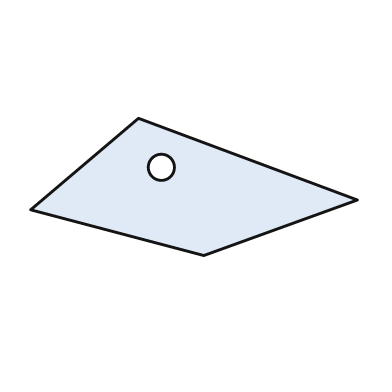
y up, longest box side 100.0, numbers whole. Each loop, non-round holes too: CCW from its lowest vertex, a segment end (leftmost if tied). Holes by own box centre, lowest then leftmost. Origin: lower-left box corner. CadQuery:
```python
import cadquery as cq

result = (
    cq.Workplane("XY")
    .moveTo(53.0, 0.0)
    .lineTo(100.0, 17.0)
    .lineTo(33.0, 42.0)
    .lineTo(0.0, 14.0)
    .close()
    .moveTo(40.0, 27.0)
    .circle(4.0)
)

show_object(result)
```